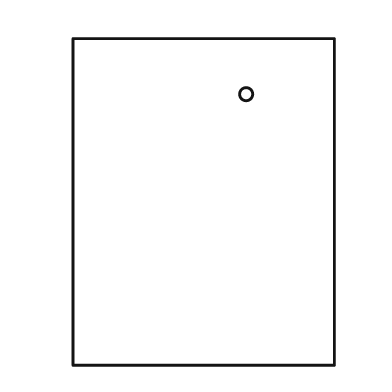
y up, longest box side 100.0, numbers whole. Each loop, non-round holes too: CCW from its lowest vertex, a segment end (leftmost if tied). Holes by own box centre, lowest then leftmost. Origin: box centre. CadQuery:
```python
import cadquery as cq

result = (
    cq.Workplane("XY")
    .moveTo(-40.0, -50.0)
    .lineTo(40.0, -50.0)
    .lineTo(40.0, 50.0)
    .lineTo(-40.0, 50.0)
    .close()
    .moveTo(13.0, 33.0)
    .circle(2.0)
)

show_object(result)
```